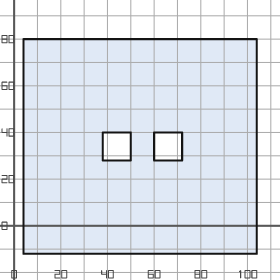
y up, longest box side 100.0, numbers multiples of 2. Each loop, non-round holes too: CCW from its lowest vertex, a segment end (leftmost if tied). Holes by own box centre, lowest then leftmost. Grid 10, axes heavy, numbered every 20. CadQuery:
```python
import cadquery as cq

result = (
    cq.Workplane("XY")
    .moveTo(4.0, -12.0)
    .lineTo(104.0, -12.0)
    .lineTo(104.0, 80.0)
    .lineTo(4.0, 80.0)
    .close()
    .moveTo(38.0, 28.0)
    .lineTo(50.0, 28.0)
    .lineTo(50.0, 40.0)
    .lineTo(38.0, 40.0)
    .close()
    .moveTo(60.0, 28.0)
    .lineTo(72.0, 28.0)
    .lineTo(72.0, 40.0)
    .lineTo(60.0, 40.0)
    .close()
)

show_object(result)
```